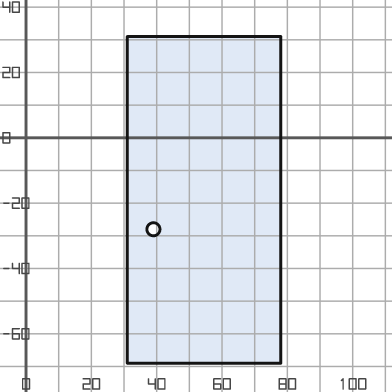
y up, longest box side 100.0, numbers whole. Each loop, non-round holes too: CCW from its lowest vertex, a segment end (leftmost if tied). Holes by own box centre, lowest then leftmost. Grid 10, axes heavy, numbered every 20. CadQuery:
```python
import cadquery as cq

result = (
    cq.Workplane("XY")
    .moveTo(31.0, -69.0)
    .lineTo(78.0, -69.0)
    .lineTo(78.0, 31.0)
    .lineTo(31.0, 31.0)
    .close()
    .moveTo(39.0, -28.0)
    .circle(2.0)
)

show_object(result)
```